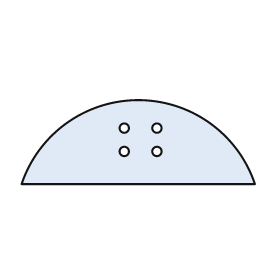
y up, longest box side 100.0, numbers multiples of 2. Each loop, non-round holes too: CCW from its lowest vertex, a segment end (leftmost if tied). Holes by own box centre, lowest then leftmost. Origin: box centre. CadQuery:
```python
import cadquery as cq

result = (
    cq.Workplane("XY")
    .moveTo(-50.0, -18.0)
    .lineTo(50.0, -18.0)
    .threePointArc((0.0, 18.0), (-50.0, -18.0))
    .close()
    .moveTo(-6.0, -4.0)
    .circle(2.0)
    .moveTo(8.0, -4.0)
    .circle(2.0)
    .moveTo(-6.0, 6.0)
    .circle(2.0)
    .moveTo(8.0, 6.0)
    .circle(2.0)
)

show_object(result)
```